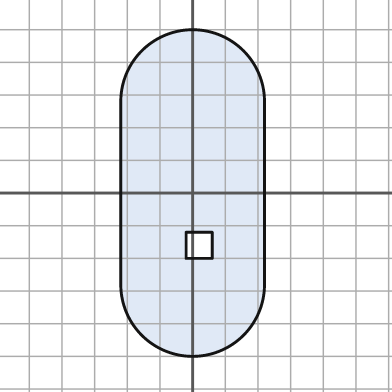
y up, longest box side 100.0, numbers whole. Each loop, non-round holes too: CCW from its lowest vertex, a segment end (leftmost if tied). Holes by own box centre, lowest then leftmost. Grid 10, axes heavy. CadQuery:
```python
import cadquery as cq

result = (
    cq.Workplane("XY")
    .moveTo(-22.0, -28.0)
    .threePointArc((0.0, -50.0), (22.0, -28.0))
    .lineTo(22.0, 28.0)
    .threePointArc((0.0, 50.0), (-22.0, 28.0))
    .close()
    .moveTo(-2.0, -20.0)
    .lineTo(6.0, -20.0)
    .lineTo(6.0, -12.0)
    .lineTo(-2.0, -12.0)
    .close()
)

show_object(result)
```